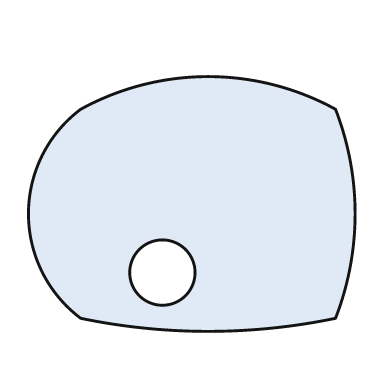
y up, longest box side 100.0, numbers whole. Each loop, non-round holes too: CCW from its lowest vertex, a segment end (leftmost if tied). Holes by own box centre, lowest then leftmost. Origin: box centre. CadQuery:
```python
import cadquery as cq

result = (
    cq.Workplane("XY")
    .moveTo(-34.0, -35.0)
    .threePointArc((5.0, -39.0), (44.0, -35.0))
    .threePointArc((50.0, -3.0), (44.0, 29.0))
    .threePointArc((5.0, 39.0), (-34.0, 29.0))
    .threePointArc((-50.0, -3.0), (-34.0, -35.0))
    .close()
    .moveTo(-9.0, -21.0)
    .circle(10.0)
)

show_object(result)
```